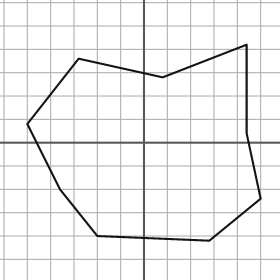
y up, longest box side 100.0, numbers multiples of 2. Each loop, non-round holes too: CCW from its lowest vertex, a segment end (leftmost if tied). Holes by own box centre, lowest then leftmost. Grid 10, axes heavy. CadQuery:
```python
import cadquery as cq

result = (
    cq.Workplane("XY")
    .moveTo(28.0, -42.0)
    .lineTo(50.0, -24.0)
    .lineTo(44.0, 4.0)
    .lineTo(44.0, 42.0)
    .lineTo(8.0, 28.0)
    .lineTo(-28.0, 36.0)
    .lineTo(-50.0, 8.0)
    .lineTo(-36.0, -20.0)
    .lineTo(-20.0, -40.0)
    .close()
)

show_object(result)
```